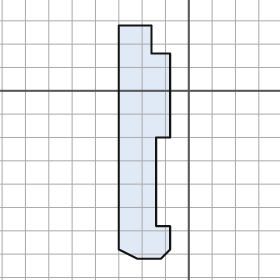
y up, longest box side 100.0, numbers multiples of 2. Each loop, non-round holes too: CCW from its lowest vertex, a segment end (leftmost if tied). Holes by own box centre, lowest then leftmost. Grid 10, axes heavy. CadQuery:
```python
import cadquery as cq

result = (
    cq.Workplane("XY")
    .moveTo(-22.0, -72.0)
    .lineTo(-12.0, -72.0)
    .lineTo(-8.0, -68.0)
    .lineTo(-8.0, -58.0)
    .lineTo(-14.0, -58.0)
    .lineTo(-14.0, -20.0)
    .lineTo(-8.0, -20.0)
    .lineTo(-8.0, 16.0)
    .lineTo(-16.0, 16.0)
    .lineTo(-16.0, 28.0)
    .lineTo(-30.0, 28.0)
    .lineTo(-30.0, -68.0)
    .close()
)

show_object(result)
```